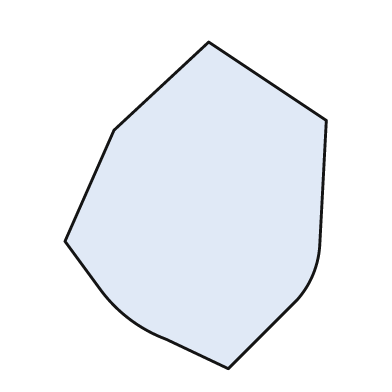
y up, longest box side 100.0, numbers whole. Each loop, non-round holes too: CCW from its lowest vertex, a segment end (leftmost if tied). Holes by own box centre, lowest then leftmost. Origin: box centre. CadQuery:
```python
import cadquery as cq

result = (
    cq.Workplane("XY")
    .moveTo(10.0, -50.0)
    .lineTo(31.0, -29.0)
    .threePointArc((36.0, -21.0), (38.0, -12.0))
    .lineTo(40.0, 26.0)
    .lineTo(4.0, 50.0)
    .lineTo(-25.0, 23.0)
    .lineTo(-40.0, -11.0)
    .lineTo(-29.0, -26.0)
    .threePointArc((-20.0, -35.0), (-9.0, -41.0))
    .close()
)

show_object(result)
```